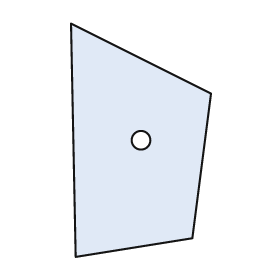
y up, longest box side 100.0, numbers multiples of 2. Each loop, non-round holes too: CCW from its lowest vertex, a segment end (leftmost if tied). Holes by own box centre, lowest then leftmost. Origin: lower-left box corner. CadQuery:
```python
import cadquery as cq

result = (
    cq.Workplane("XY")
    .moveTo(2.0, 0.0)
    .lineTo(52.0, 8.0)
    .lineTo(60.0, 70.0)
    .lineTo(0.0, 100.0)
    .close()
    .moveTo(30.0, 50.0)
    .circle(4.0)
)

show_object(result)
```